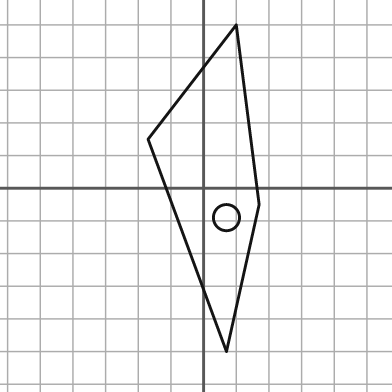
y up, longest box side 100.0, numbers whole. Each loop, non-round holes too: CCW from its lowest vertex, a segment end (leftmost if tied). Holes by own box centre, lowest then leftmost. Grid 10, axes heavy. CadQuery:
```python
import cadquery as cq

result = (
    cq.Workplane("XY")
    .moveTo(7.0, -50.0)
    .lineTo(17.0, -5.0)
    .lineTo(10.0, 50.0)
    .lineTo(-17.0, 15.0)
    .close()
    .moveTo(7.0, -9.0)
    .circle(4.0)
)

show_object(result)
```